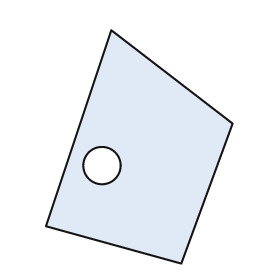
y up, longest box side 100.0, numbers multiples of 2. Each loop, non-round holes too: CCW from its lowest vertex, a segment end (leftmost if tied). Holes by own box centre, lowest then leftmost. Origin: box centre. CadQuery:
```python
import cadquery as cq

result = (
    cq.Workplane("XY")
    .moveTo(18.0, -50.0)
    .lineTo(40.0, 10.0)
    .lineTo(-12.0, 50.0)
    .lineTo(-40.0, -34.0)
    .close()
    .moveTo(-16.0, -8.0)
    .circle(8.0)
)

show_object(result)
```